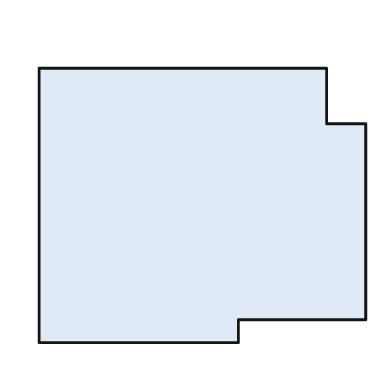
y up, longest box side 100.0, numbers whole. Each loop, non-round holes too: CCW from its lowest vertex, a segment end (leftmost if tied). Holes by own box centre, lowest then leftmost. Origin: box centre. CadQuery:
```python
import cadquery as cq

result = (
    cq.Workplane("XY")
    .moveTo(-50.0, -42.0)
    .lineTo(11.0, -42.0)
    .lineTo(11.0, -35.0)
    .lineTo(50.0, -35.0)
    .lineTo(50.0, 25.0)
    .lineTo(38.0, 25.0)
    .lineTo(38.0, 42.0)
    .lineTo(-50.0, 42.0)
    .close()
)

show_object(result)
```